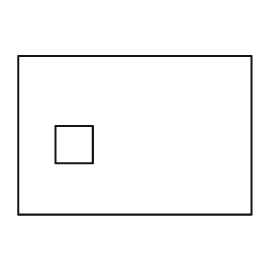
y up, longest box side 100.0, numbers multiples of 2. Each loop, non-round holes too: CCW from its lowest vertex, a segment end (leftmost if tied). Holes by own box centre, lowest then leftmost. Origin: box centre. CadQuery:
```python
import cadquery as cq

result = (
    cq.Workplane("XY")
    .moveTo(-50.0, -34.0)
    .lineTo(50.0, -34.0)
    .lineTo(50.0, 34.0)
    .lineTo(-50.0, 34.0)
    .close()
    .moveTo(-34.0, -12.0)
    .lineTo(-18.0, -12.0)
    .lineTo(-18.0, 4.0)
    .lineTo(-34.0, 4.0)
    .close()
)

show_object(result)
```